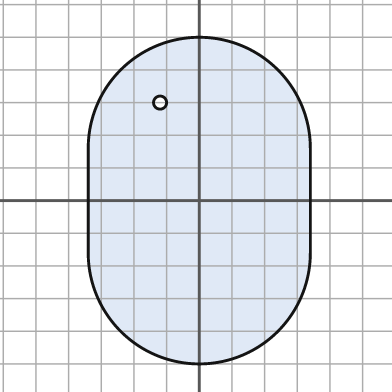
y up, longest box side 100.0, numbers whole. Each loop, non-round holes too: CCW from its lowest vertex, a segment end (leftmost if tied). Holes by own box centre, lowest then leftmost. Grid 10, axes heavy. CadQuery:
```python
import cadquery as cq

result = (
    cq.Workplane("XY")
    .moveTo(-34.0, -16.0)
    .threePointArc((0.0, -50.0), (34.0, -16.0))
    .lineTo(34.0, 16.0)
    .threePointArc((0.0, 50.0), (-34.0, 16.0))
    .close()
    .moveTo(-12.0, 30.0)
    .circle(2.0)
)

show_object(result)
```